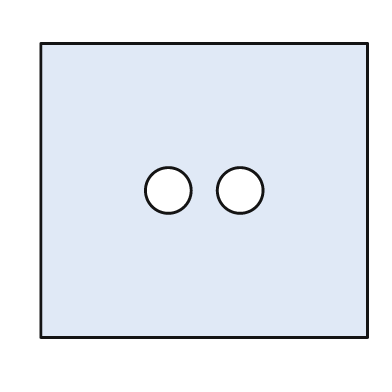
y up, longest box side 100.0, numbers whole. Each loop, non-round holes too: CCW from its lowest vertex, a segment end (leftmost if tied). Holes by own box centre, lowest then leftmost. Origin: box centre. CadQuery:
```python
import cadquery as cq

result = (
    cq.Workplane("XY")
    .moveTo(-50.0, -45.0)
    .lineTo(50.0, -45.0)
    .lineTo(50.0, 45.0)
    .lineTo(-50.0, 45.0)
    .close()
    .moveTo(-11.0, 0.0)
    .circle(7.0)
    .moveTo(11.0, 0.0)
    .circle(7.0)
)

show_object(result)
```